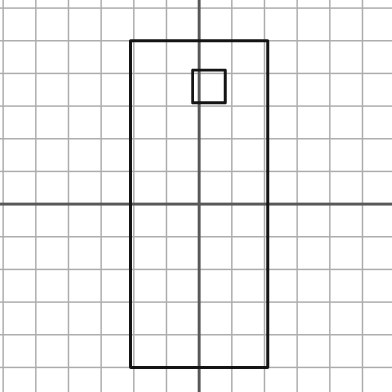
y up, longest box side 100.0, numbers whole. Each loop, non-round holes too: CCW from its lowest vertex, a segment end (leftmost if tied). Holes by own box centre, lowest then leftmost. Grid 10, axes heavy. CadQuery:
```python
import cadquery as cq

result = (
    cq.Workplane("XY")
    .moveTo(-21.0, -50.0)
    .lineTo(21.0, -50.0)
    .lineTo(21.0, 50.0)
    .lineTo(-21.0, 50.0)
    .close()
    .moveTo(-2.0, 31.0)
    .lineTo(8.0, 31.0)
    .lineTo(8.0, 41.0)
    .lineTo(-2.0, 41.0)
    .close()
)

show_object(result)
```